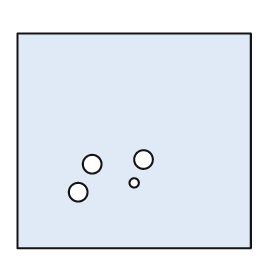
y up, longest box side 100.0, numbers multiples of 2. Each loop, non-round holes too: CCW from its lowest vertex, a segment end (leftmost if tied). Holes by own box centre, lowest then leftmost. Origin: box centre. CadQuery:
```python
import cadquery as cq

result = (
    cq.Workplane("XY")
    .moveTo(-50.0, -46.0)
    .lineTo(50.0, -46.0)
    .lineTo(50.0, 46.0)
    .lineTo(-50.0, 46.0)
    .close()
    .moveTo(-24.0, -22.0)
    .circle(4.0)
    .moveTo(0.0, -18.0)
    .circle(2.0)
    .moveTo(-18.0, -10.0)
    .circle(4.0)
    .moveTo(4.0, -8.0)
    .circle(4.0)
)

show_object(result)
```